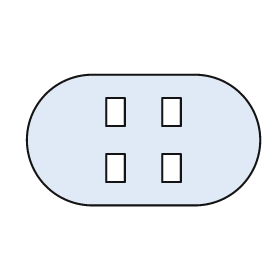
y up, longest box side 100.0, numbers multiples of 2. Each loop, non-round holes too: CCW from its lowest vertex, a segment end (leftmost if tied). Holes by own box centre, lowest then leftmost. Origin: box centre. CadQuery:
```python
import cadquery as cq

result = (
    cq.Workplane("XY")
    .moveTo(-22.0, -28.0)
    .lineTo(22.0, -28.0)
    .threePointArc((50.0, 0.0), (22.0, 28.0))
    .lineTo(-22.0, 28.0)
    .threePointArc((-50.0, 0.0), (-22.0, -28.0))
    .close()
    .moveTo(-16.0, -18.0)
    .lineTo(-8.0, -18.0)
    .lineTo(-8.0, -6.0)
    .lineTo(-16.0, -6.0)
    .close()
    .moveTo(8.0, -18.0)
    .lineTo(16.0, -18.0)
    .lineTo(16.0, -6.0)
    .lineTo(8.0, -6.0)
    .close()
    .moveTo(-16.0, 6.0)
    .lineTo(-8.0, 6.0)
    .lineTo(-8.0, 18.0)
    .lineTo(-16.0, 18.0)
    .close()
    .moveTo(8.0, 6.0)
    .lineTo(16.0, 6.0)
    .lineTo(16.0, 18.0)
    .lineTo(8.0, 18.0)
    .close()
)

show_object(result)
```